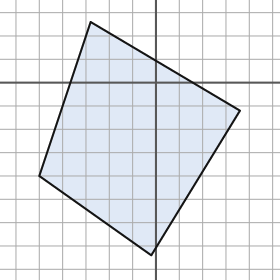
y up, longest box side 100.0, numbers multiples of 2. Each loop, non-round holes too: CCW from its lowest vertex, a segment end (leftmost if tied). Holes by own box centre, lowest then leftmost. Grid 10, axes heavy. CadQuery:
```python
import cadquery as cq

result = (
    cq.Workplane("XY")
    .moveTo(-2.0, -74.0)
    .lineTo(36.0, -12.0)
    .lineTo(-28.0, 26.0)
    .lineTo(-50.0, -40.0)
    .close()
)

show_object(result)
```